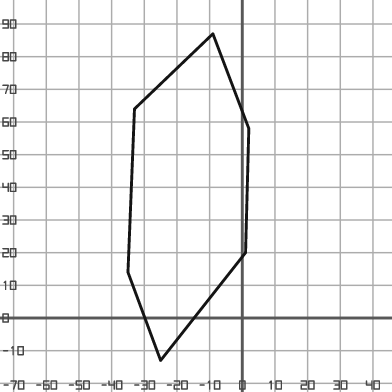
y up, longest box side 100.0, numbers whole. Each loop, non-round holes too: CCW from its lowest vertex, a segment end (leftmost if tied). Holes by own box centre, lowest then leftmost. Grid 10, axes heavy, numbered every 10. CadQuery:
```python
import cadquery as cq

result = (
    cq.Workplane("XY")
    .moveTo(-25.0, -13.0)
    .lineTo(1.0, 20.0)
    .lineTo(2.0, 58.0)
    .lineTo(-9.0, 87.0)
    .lineTo(-33.0, 64.0)
    .lineTo(-35.0, 14.0)
    .close()
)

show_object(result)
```